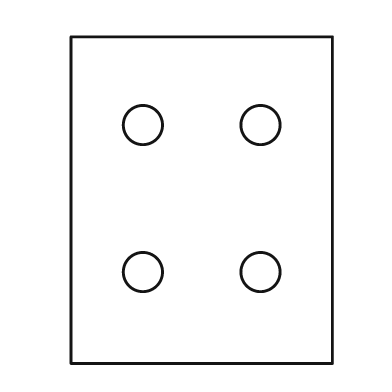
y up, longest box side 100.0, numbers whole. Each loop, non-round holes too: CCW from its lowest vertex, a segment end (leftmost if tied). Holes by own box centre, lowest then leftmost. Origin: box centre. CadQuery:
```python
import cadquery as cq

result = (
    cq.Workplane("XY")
    .moveTo(-40.0, -50.0)
    .lineTo(40.0, -50.0)
    .lineTo(40.0, 50.0)
    .lineTo(-40.0, 50.0)
    .close()
    .moveTo(-18.0, -22.0)
    .circle(6.0)
    .moveTo(18.0, -22.0)
    .circle(6.0)
    .moveTo(-18.0, 23.0)
    .circle(6.0)
    .moveTo(18.0, 23.0)
    .circle(6.0)
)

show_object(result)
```